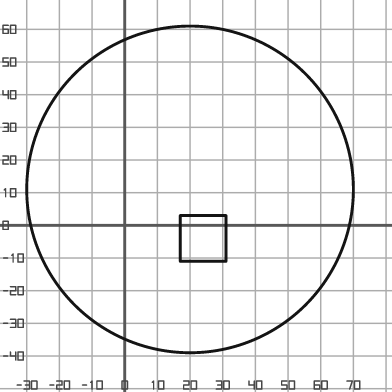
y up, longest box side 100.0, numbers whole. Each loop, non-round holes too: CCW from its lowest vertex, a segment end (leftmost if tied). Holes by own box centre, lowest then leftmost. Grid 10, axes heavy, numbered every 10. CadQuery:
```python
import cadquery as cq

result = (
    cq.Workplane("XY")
    .moveTo(20.0, 11.0)
    .circle(50.0)
    .moveTo(17.0, -11.0)
    .lineTo(31.0, -11.0)
    .lineTo(31.0, 3.0)
    .lineTo(17.0, 3.0)
    .close()
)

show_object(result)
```